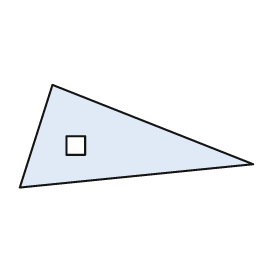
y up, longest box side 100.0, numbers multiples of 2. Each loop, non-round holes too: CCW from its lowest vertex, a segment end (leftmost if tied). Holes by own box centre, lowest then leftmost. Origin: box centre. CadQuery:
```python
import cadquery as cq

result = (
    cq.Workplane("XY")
    .moveTo(-50.0, -22.0)
    .lineTo(50.0, -12.0)
    .lineTo(-36.0, 22.0)
    .close()
    .moveTo(-30.0, -8.0)
    .lineTo(-22.0, -8.0)
    .lineTo(-22.0, 0.0)
    .lineTo(-30.0, 0.0)
    .close()
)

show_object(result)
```